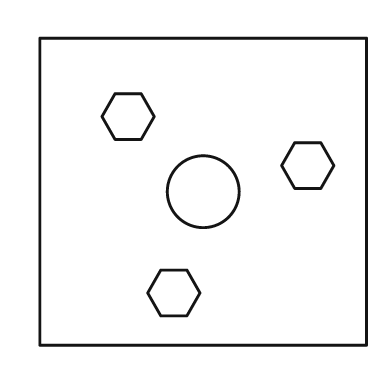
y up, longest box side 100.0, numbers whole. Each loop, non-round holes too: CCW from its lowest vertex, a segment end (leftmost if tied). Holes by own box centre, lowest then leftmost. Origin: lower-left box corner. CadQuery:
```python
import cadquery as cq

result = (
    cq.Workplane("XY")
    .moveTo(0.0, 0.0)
    .lineTo(100.0, 0.0)
    .lineTo(100.0, 94.0)
    .lineTo(0.0, 94.0)
    .close()
    .moveTo(37.0, 9.0)
    .lineTo(45.0, 9.0)
    .lineTo(49.0, 16.0)
    .lineTo(45.0, 23.0)
    .lineTo(37.0, 23.0)
    .lineTo(33.0, 16.0)
    .close()
    .moveTo(50.0, 47.0)
    .circle(11.0)
    .moveTo(78.0, 48.0)
    .lineTo(86.0, 48.0)
    .lineTo(90.0, 55.0)
    .lineTo(86.0, 62.0)
    .lineTo(78.0, 62.0)
    .lineTo(74.0, 55.0)
    .close()
    .moveTo(23.0, 63.0)
    .lineTo(31.0, 63.0)
    .lineTo(35.0, 70.0)
    .lineTo(31.0, 77.0)
    .lineTo(23.0, 77.0)
    .lineTo(19.0, 70.0)
    .close()
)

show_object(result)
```